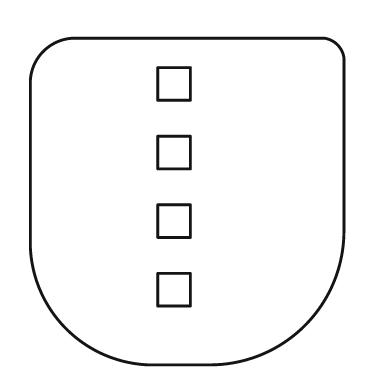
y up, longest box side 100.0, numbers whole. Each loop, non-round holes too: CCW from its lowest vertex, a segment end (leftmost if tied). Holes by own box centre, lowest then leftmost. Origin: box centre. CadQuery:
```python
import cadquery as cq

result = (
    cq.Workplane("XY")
    .moveTo(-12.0, -50.0)
    .lineTo(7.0, -50.0)
    .threePointArc((36.0, -38.0), (48.0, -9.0))
    .lineTo(48.0, 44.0)
    .threePointArc((46.0, 48.0), (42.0, 50.0))
    .lineTo(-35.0, 50.0)
    .threePointArc((-44.0, 46.0), (-48.0, 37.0))
    .lineTo(-48.0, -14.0)
    .threePointArc((-37.0, -39.0), (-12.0, -50.0))
    .close()
    .moveTo(-9.0, -32.0)
    .lineTo(1.0, -32.0)
    .lineTo(1.0, -22.0)
    .lineTo(-9.0, -22.0)
    .close()
    .moveTo(-9.0, -11.0)
    .lineTo(1.0, -11.0)
    .lineTo(1.0, -1.0)
    .lineTo(-9.0, -1.0)
    .close()
    .moveTo(-9.0, 10.0)
    .lineTo(1.0, 10.0)
    .lineTo(1.0, 20.0)
    .lineTo(-9.0, 20.0)
    .close()
    .moveTo(-9.0, 31.0)
    .lineTo(1.0, 31.0)
    .lineTo(1.0, 41.0)
    .lineTo(-9.0, 41.0)
    .close()
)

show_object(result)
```